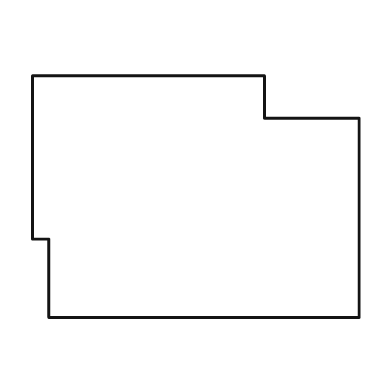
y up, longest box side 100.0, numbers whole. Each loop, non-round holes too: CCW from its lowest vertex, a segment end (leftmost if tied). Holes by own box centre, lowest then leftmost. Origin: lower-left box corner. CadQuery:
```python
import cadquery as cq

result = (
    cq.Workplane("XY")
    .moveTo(5.0, 0.0)
    .lineTo(100.0, 0.0)
    .lineTo(100.0, 61.0)
    .lineTo(71.0, 61.0)
    .lineTo(71.0, 74.0)
    .lineTo(0.0, 74.0)
    .lineTo(0.0, 24.0)
    .lineTo(5.0, 24.0)
    .close()
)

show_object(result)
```